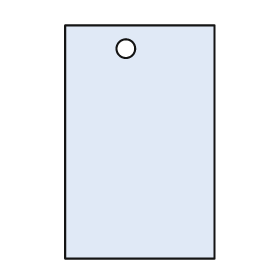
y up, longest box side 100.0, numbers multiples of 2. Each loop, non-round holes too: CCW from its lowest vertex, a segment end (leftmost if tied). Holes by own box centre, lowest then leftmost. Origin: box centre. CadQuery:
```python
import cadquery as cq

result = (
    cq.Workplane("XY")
    .moveTo(-32.0, -50.0)
    .lineTo(32.0, -50.0)
    .lineTo(32.0, 50.0)
    .lineTo(-32.0, 50.0)
    .close()
    .moveTo(-6.0, 40.0)
    .circle(4.0)
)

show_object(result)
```